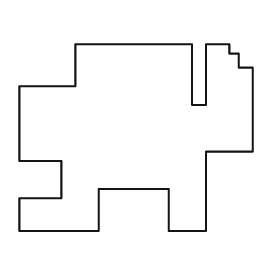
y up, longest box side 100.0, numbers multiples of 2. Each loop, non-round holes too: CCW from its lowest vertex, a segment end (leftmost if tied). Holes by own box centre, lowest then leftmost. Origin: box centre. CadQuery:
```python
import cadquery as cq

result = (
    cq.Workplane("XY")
    .moveTo(-50.0, -40.0)
    .lineTo(-16.0, -40.0)
    .lineTo(-16.0, -22.0)
    .lineTo(14.0, -22.0)
    .lineTo(14.0, -40.0)
    .lineTo(30.0, -40.0)
    .lineTo(30.0, -6.0)
    .lineTo(50.0, -6.0)
    .lineTo(50.0, 30.0)
    .lineTo(44.0, 30.0)
    .lineTo(44.0, 36.0)
    .lineTo(40.0, 36.0)
    .lineTo(40.0, 40.0)
    .lineTo(30.0, 40.0)
    .lineTo(30.0, 14.0)
    .lineTo(24.0, 14.0)
    .lineTo(24.0, 40.0)
    .lineTo(-26.0, 40.0)
    .lineTo(-26.0, 22.0)
    .lineTo(-50.0, 22.0)
    .lineTo(-50.0, -10.0)
    .lineTo(-32.0, -10.0)
    .lineTo(-32.0, -26.0)
    .lineTo(-50.0, -26.0)
    .close()
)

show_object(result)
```